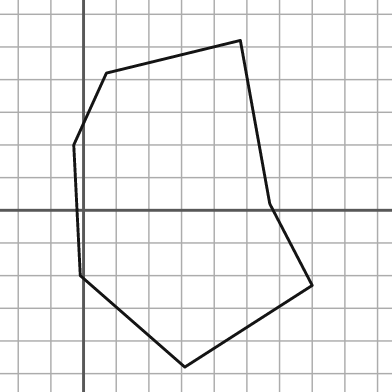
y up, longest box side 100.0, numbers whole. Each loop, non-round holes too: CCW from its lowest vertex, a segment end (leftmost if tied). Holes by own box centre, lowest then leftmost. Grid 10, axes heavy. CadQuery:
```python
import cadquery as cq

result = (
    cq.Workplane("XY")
    .moveTo(31.0, -48.0)
    .lineTo(70.0, -23.0)
    .lineTo(57.0, 2.0)
    .lineTo(48.0, 52.0)
    .lineTo(7.0, 42.0)
    .lineTo(-3.0, 20.0)
    .lineTo(-1.0, -20.0)
    .close()
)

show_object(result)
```